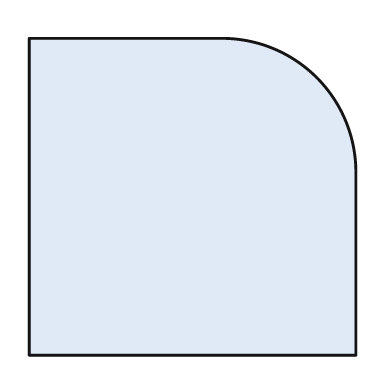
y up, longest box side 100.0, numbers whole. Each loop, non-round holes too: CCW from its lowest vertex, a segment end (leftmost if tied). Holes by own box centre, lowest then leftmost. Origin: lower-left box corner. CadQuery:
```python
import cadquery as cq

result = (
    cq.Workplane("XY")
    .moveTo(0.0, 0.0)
    .lineTo(100.0, 0.0)
    .lineTo(100.0, 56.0)
    .threePointArc((88.0, 85.0), (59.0, 97.0))
    .lineTo(0.0, 97.0)
    .close()
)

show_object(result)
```